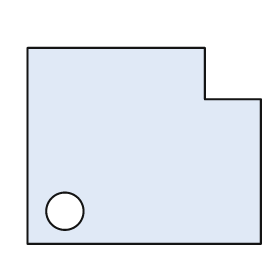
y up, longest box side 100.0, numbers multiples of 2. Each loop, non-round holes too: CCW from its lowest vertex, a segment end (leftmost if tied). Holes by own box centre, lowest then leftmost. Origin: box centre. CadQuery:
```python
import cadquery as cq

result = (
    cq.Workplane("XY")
    .moveTo(-50.0, -42.0)
    .lineTo(50.0, -42.0)
    .lineTo(50.0, 20.0)
    .lineTo(26.0, 20.0)
    .lineTo(26.0, 42.0)
    .lineTo(-50.0, 42.0)
    .close()
    .moveTo(-34.0, -28.0)
    .circle(8.0)
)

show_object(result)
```